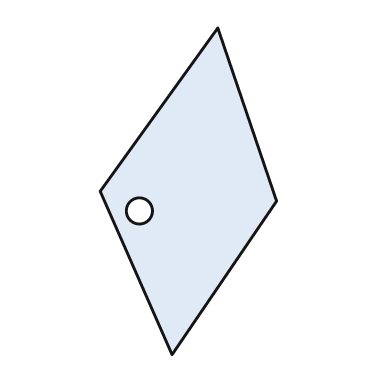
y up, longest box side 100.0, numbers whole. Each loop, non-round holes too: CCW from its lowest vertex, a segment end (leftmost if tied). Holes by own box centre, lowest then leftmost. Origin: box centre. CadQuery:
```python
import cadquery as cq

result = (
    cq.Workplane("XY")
    .moveTo(-5.0, -50.0)
    .lineTo(27.0, -3.0)
    .lineTo(9.0, 50.0)
    .lineTo(-27.0, 0.0)
    .close()
    .moveTo(-15.0, -6.0)
    .circle(4.0)
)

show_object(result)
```